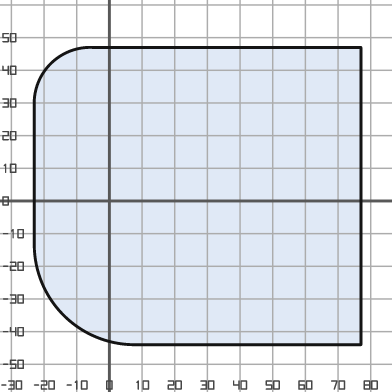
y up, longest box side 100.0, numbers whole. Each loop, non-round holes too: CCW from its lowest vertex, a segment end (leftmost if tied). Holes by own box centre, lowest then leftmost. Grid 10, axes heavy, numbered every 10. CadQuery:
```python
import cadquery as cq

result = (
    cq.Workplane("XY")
    .moveTo(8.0, -44.0)
    .lineTo(77.0, -44.0)
    .lineTo(77.0, 47.0)
    .lineTo(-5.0, 47.0)
    .threePointArc((-18.0, 42.0), (-23.0, 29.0))
    .lineTo(-23.0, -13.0)
    .threePointArc((-14.0, -35.0), (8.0, -44.0))
    .close()
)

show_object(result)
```